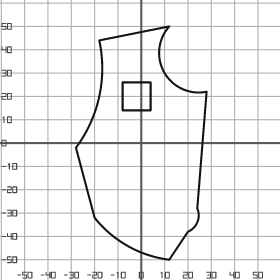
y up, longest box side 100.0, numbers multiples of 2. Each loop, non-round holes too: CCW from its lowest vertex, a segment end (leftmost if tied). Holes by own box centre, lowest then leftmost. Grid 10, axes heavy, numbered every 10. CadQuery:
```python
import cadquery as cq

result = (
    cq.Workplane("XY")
    .moveTo(12.0, -50.0)
    .lineTo(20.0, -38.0)
    .threePointArc((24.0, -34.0), (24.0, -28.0))
    .lineTo(28.0, 22.0)
    .threePointArc((10.0, 30.0), (12.0, 50.0))
    .lineTo(-18.0, 44.0)
    .threePointArc((-18.0, 20.0), (-28.0, -2.0))
    .lineTo(-20.0, -32.0)
    .threePointArc((-6.0, -44.0), (12.0, -50.0))
    .close()
    .moveTo(-8.0, 14.0)
    .lineTo(4.0, 14.0)
    .lineTo(4.0, 26.0)
    .lineTo(-8.0, 26.0)
    .close()
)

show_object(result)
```